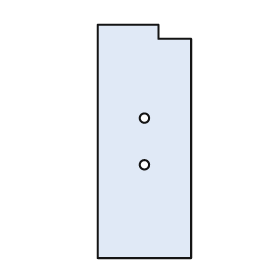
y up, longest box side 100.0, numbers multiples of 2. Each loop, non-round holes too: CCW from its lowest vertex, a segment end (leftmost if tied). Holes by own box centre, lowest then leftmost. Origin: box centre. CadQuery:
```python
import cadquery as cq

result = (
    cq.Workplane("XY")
    .moveTo(-20.0, -50.0)
    .lineTo(20.0, -50.0)
    .lineTo(20.0, 44.0)
    .lineTo(6.0, 44.0)
    .lineTo(6.0, 50.0)
    .lineTo(-20.0, 50.0)
    .close()
    .moveTo(0.0, -10.0)
    .circle(2.0)
    .moveTo(0.0, 10.0)
    .circle(2.0)
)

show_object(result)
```